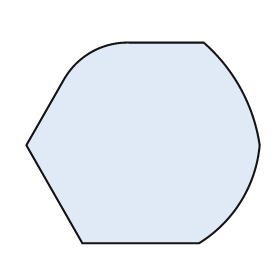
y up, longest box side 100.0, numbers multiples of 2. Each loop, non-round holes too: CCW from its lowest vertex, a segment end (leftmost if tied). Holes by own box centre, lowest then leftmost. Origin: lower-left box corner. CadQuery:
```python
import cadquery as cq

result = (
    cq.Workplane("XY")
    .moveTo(24.0, 0.0)
    .lineTo(74.0, 0.0)
    .threePointArc((92.0, 18.0), (100.0, 42.0))
    .threePointArc((92.0, 66.0), (76.0, 86.0))
    .lineTo(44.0, 86.0)
    .threePointArc((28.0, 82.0), (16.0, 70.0))
    .lineTo(0.0, 42.0)
    .close()
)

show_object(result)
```